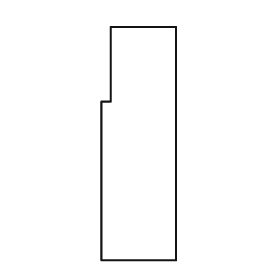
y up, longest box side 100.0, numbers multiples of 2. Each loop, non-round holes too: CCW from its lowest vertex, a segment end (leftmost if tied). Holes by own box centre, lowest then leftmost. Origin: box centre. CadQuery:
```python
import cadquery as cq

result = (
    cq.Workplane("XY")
    .moveTo(-16.0, -50.0)
    .lineTo(16.0, -50.0)
    .lineTo(16.0, 50.0)
    .lineTo(-12.0, 50.0)
    .lineTo(-12.0, 18.0)
    .lineTo(-16.0, 18.0)
    .close()
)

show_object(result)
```